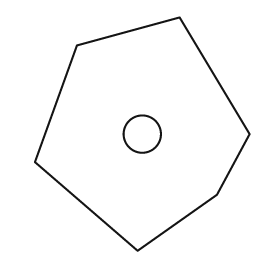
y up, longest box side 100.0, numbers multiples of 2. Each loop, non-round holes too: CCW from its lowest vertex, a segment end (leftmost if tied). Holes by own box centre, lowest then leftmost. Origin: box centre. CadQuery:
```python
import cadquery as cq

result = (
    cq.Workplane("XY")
    .moveTo(-2.0, -50.0)
    .lineTo(32.0, -26.0)
    .lineTo(46.0, 0.0)
    .lineTo(16.0, 50.0)
    .lineTo(-28.0, 38.0)
    .lineTo(-46.0, -12.0)
    .close()
    .moveTo(0.0, 0.0)
    .circle(8.0)
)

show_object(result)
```